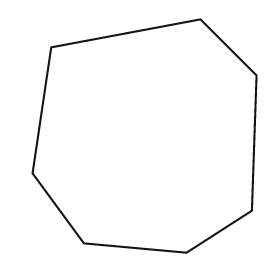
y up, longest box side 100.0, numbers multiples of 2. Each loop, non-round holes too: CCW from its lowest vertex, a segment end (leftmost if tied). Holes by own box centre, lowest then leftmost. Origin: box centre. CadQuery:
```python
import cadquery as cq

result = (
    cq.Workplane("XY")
    .moveTo(18.0, -50.0)
    .lineTo(46.0, -32.0)
    .lineTo(48.0, 26.0)
    .lineTo(24.0, 50.0)
    .lineTo(-40.0, 38.0)
    .lineTo(-48.0, -16.0)
    .lineTo(-26.0, -46.0)
    .close()
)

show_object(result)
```